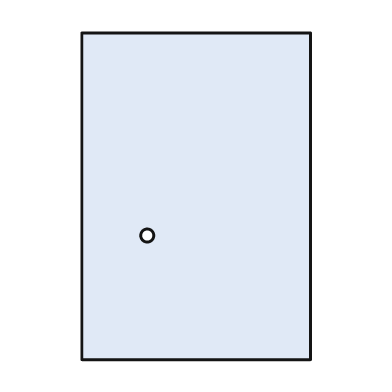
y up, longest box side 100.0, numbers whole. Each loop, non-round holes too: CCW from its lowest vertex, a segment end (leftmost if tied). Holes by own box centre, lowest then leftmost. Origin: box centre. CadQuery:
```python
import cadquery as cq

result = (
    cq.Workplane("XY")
    .moveTo(-35.0, -50.0)
    .lineTo(35.0, -50.0)
    .lineTo(35.0, 50.0)
    .lineTo(-35.0, 50.0)
    .close()
    .moveTo(-15.0, -12.0)
    .circle(2.0)
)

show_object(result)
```